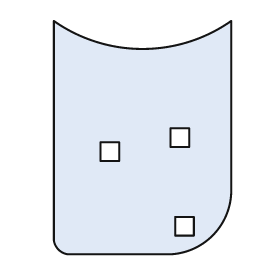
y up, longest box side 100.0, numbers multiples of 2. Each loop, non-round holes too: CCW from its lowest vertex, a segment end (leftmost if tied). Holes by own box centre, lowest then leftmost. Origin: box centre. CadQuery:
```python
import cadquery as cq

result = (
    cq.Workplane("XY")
    .moveTo(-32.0, -50.0)
    .lineTo(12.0, -50.0)
    .threePointArc((30.0, -42.0), (38.0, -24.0))
    .lineTo(38.0, 50.0)
    .threePointArc((0.0, 38.0), (-38.0, 50.0))
    .lineTo(-38.0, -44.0)
    .threePointArc((-36.0, -48.0), (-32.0, -50.0))
    .close()
    .moveTo(14.0, -42.0)
    .lineTo(22.0, -42.0)
    .lineTo(22.0, -34.0)
    .lineTo(14.0, -34.0)
    .close()
    .moveTo(-18.0, -10.0)
    .lineTo(-10.0, -10.0)
    .lineTo(-10.0, -2.0)
    .lineTo(-18.0, -2.0)
    .close()
    .moveTo(12.0, -4.0)
    .lineTo(20.0, -4.0)
    .lineTo(20.0, 4.0)
    .lineTo(12.0, 4.0)
    .close()
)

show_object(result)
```